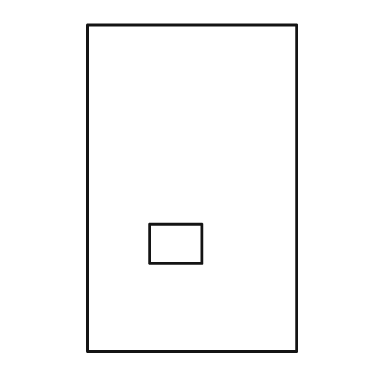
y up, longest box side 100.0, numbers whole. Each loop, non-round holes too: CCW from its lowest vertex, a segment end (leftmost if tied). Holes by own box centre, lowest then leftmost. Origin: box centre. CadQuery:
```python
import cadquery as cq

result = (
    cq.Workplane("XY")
    .moveTo(-32.0, -50.0)
    .lineTo(32.0, -50.0)
    .lineTo(32.0, 50.0)
    .lineTo(-32.0, 50.0)
    .close()
    .moveTo(-13.0, -23.0)
    .lineTo(3.0, -23.0)
    .lineTo(3.0, -11.0)
    .lineTo(-13.0, -11.0)
    .close()
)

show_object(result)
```